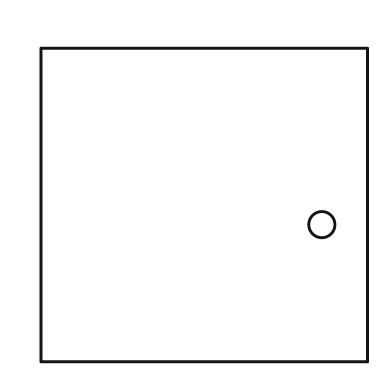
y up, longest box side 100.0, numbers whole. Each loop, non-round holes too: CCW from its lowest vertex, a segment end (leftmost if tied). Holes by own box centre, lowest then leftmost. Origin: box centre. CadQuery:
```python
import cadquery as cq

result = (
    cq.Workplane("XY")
    .moveTo(-50.0, -48.0)
    .lineTo(50.0, -48.0)
    .lineTo(50.0, 48.0)
    .lineTo(-50.0, 48.0)
    .close()
    .moveTo(36.0, -6.0)
    .circle(4.0)
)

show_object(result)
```